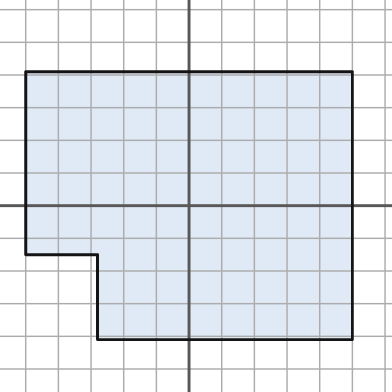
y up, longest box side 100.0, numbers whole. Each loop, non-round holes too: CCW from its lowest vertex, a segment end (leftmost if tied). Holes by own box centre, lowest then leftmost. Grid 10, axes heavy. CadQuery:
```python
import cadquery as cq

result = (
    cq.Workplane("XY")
    .moveTo(-28.0, -41.0)
    .lineTo(50.0, -41.0)
    .lineTo(50.0, 41.0)
    .lineTo(-50.0, 41.0)
    .lineTo(-50.0, -15.0)
    .lineTo(-28.0, -15.0)
    .close()
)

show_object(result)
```